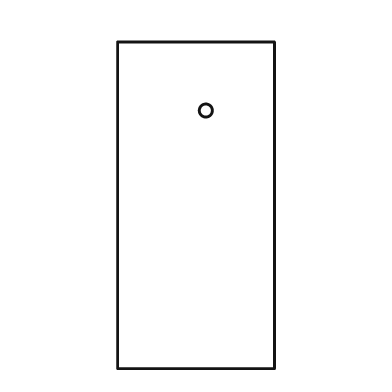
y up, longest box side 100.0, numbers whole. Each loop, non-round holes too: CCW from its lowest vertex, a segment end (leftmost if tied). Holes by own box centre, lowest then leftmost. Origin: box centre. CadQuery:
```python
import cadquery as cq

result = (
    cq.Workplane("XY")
    .moveTo(-24.0, -50.0)
    .lineTo(24.0, -50.0)
    .lineTo(24.0, 50.0)
    .lineTo(-24.0, 50.0)
    .close()
    .moveTo(3.0, 29.0)
    .circle(2.0)
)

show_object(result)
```